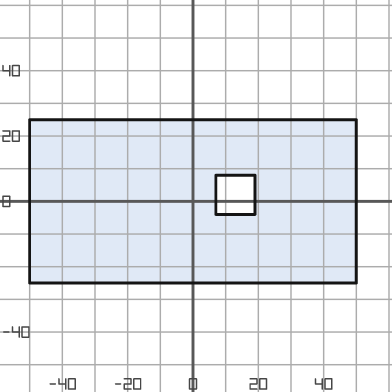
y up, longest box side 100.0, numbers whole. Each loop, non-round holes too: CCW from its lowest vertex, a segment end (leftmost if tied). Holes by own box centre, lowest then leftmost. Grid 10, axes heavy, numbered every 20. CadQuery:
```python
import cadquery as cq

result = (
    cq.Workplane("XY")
    .moveTo(-50.0, -25.0)
    .lineTo(50.0, -25.0)
    .lineTo(50.0, 25.0)
    .lineTo(-50.0, 25.0)
    .close()
    .moveTo(7.0, -4.0)
    .lineTo(19.0, -4.0)
    .lineTo(19.0, 8.0)
    .lineTo(7.0, 8.0)
    .close()
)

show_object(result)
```